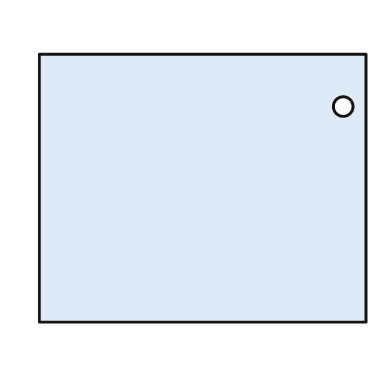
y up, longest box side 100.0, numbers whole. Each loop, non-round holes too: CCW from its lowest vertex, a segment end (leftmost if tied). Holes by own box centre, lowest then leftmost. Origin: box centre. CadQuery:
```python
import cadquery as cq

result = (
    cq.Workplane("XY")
    .moveTo(-50.0, -41.0)
    .lineTo(50.0, -41.0)
    .lineTo(50.0, 41.0)
    .lineTo(-50.0, 41.0)
    .close()
    .moveTo(43.0, 25.0)
    .circle(3.0)
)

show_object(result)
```